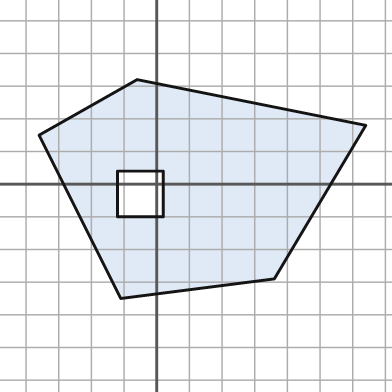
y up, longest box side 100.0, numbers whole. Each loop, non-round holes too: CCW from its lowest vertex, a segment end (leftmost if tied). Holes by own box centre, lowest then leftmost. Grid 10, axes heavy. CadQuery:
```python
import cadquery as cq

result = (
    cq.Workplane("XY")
    .moveTo(-11.0, -35.0)
    .lineTo(36.0, -29.0)
    .lineTo(64.0, 18.0)
    .lineTo(-6.0, 32.0)
    .lineTo(-36.0, 15.0)
    .close()
    .moveTo(-12.0, -10.0)
    .lineTo(2.0, -10.0)
    .lineTo(2.0, 4.0)
    .lineTo(-12.0, 4.0)
    .close()
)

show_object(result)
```